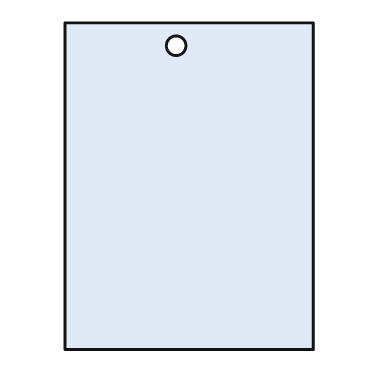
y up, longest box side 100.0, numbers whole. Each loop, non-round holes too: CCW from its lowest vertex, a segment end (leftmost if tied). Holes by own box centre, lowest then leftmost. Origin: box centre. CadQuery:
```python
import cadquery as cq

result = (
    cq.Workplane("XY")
    .moveTo(-38.0, -50.0)
    .lineTo(38.0, -50.0)
    .lineTo(38.0, 50.0)
    .lineTo(-38.0, 50.0)
    .close()
    .moveTo(-4.0, 43.0)
    .circle(3.0)
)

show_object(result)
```